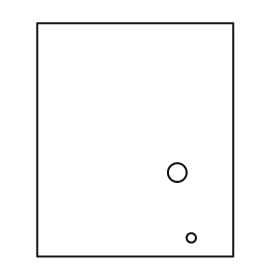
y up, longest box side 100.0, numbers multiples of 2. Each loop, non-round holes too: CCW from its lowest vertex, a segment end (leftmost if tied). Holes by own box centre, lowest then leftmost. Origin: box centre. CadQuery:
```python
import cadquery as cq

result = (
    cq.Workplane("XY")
    .moveTo(-42.0, -50.0)
    .lineTo(42.0, -50.0)
    .lineTo(42.0, 50.0)
    .lineTo(-42.0, 50.0)
    .close()
    .moveTo(24.0, -42.0)
    .circle(2.0)
    .moveTo(18.0, -14.0)
    .circle(4.0)
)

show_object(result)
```